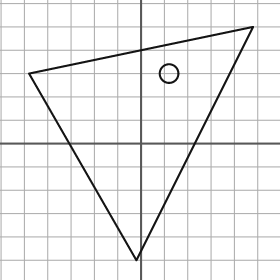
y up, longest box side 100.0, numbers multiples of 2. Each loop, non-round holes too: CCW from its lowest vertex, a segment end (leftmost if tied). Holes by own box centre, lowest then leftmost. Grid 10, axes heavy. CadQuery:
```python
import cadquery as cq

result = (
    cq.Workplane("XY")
    .moveTo(-2.0, -50.0)
    .lineTo(48.0, 50.0)
    .lineTo(-48.0, 30.0)
    .close()
    .moveTo(12.0, 30.0)
    .circle(4.0)
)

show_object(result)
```